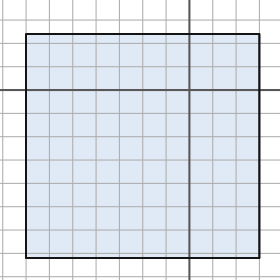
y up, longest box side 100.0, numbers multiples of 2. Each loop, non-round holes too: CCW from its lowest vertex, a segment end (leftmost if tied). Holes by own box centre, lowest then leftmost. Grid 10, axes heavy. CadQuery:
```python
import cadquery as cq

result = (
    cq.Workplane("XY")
    .moveTo(-70.0, -72.0)
    .lineTo(30.0, -72.0)
    .lineTo(30.0, 24.0)
    .lineTo(-70.0, 24.0)
    .close()
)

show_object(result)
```